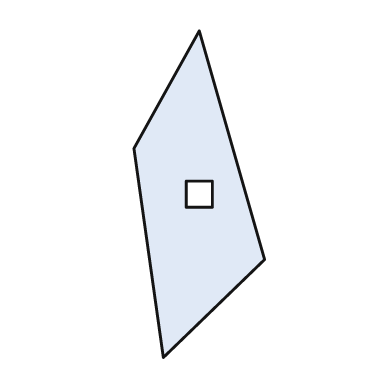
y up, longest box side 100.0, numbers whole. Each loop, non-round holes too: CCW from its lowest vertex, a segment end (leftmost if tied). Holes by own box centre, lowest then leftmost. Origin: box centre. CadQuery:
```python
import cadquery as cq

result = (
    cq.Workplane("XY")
    .moveTo(-11.0, -50.0)
    .lineTo(20.0, -20.0)
    .lineTo(0.0, 50.0)
    .lineTo(-20.0, 14.0)
    .close()
    .moveTo(-4.0, -4.0)
    .lineTo(4.0, -4.0)
    .lineTo(4.0, 4.0)
    .lineTo(-4.0, 4.0)
    .close()
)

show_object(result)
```